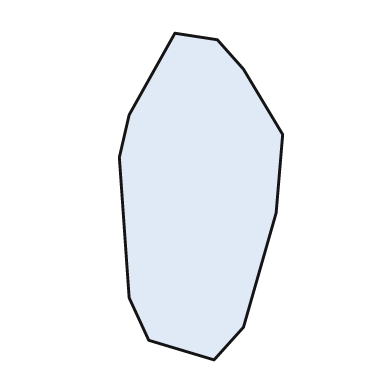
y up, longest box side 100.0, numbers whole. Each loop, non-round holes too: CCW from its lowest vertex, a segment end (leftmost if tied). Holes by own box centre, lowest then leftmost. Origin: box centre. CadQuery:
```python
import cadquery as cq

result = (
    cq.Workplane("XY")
    .moveTo(4.0, -50.0)
    .lineTo(13.0, -40.0)
    .lineTo(23.0, -5.0)
    .lineTo(25.0, 19.0)
    .lineTo(13.0, 39.0)
    .lineTo(5.0, 48.0)
    .lineTo(-8.0, 50.0)
    .lineTo(-22.0, 25.0)
    .lineTo(-25.0, 12.0)
    .lineTo(-22.0, -31.0)
    .lineTo(-16.0, -44.0)
    .close()
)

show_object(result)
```